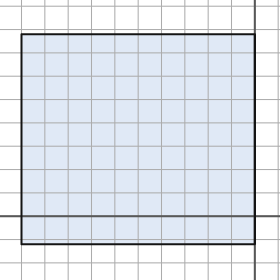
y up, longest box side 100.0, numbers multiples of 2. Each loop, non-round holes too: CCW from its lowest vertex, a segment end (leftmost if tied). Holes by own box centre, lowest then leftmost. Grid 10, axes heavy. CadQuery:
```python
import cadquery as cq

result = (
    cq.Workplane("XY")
    .moveTo(-100.0, -12.0)
    .lineTo(0.0, -12.0)
    .lineTo(0.0, 78.0)
    .lineTo(-100.0, 78.0)
    .close()
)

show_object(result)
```